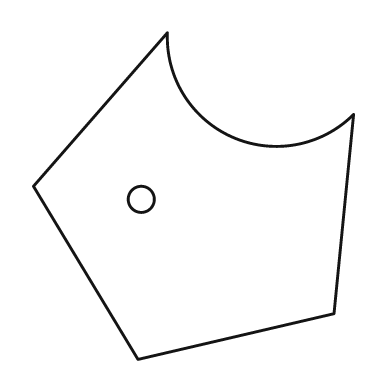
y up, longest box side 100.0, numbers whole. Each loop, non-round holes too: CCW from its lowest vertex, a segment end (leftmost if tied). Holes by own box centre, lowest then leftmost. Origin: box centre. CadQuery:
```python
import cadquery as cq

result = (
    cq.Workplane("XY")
    .moveTo(-17.0, -50.0)
    .lineTo(43.0, -36.0)
    .lineTo(49.0, 25.0)
    .threePointArc((12.0, 18.0), (-8.0, 50.0))
    .lineTo(-49.0, 3.0)
    .close()
    .moveTo(-16.0, -1.0)
    .circle(4.0)
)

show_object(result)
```